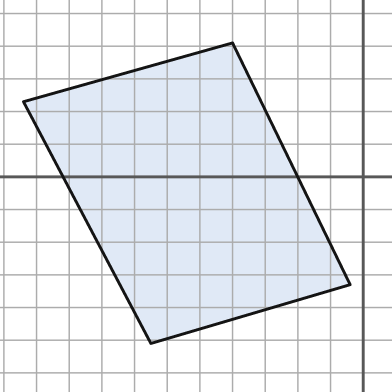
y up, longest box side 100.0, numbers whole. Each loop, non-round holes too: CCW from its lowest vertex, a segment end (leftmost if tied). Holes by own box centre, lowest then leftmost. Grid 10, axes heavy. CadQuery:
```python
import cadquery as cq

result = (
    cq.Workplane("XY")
    .moveTo(-65.0, -51.0)
    .lineTo(-4.0, -33.0)
    .lineTo(-40.0, 41.0)
    .lineTo(-104.0, 23.0)
    .close()
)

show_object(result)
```